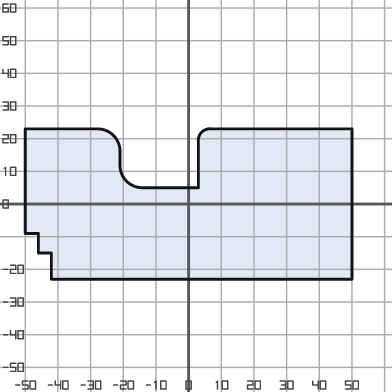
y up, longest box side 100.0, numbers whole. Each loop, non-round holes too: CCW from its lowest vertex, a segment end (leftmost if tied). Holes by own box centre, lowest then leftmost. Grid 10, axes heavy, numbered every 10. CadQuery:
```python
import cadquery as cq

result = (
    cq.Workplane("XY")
    .moveTo(-42.0, -23.0)
    .lineTo(50.0, -23.0)
    .lineTo(50.0, 23.0)
    .lineTo(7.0, 23.0)
    .threePointArc((4.0, 22.0), (3.0, 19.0))
    .lineTo(3.0, 5.0)
    .lineTo(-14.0, 5.0)
    .threePointArc((-19.0, 7.0), (-21.0, 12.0))
    .lineTo(-21.0, 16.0)
    .threePointArc((-23.0, 21.0), (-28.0, 23.0))
    .lineTo(-50.0, 23.0)
    .lineTo(-50.0, -9.0)
    .lineTo(-46.0, -9.0)
    .lineTo(-46.0, -15.0)
    .lineTo(-42.0, -15.0)
    .close()
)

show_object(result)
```